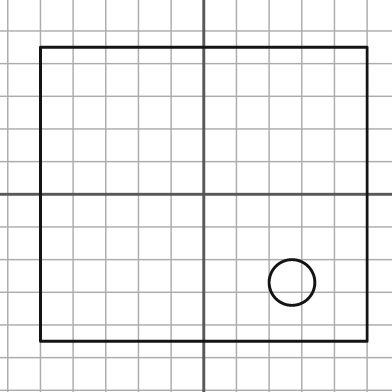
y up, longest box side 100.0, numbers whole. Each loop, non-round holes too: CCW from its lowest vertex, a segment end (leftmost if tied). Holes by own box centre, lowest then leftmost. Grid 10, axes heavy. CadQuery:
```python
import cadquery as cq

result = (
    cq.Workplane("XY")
    .moveTo(-50.0, -45.0)
    .lineTo(50.0, -45.0)
    .lineTo(50.0, 45.0)
    .lineTo(-50.0, 45.0)
    .close()
    .moveTo(27.0, -27.0)
    .circle(7.0)
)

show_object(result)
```